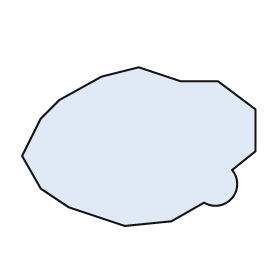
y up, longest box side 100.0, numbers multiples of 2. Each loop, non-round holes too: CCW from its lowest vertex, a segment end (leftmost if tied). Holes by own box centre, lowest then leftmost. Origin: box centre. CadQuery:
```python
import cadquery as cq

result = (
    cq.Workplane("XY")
    .moveTo(-6.0, -34.0)
    .lineTo(14.0, -32.0)
    .lineTo(28.0, -24.0)
    .threePointArc((40.0, -22.0), (40.0, -10.0))
    .lineTo(50.0, -2.0)
    .lineTo(50.0, 16.0)
    .lineTo(34.0, 28.0)
    .lineTo(18.0, 28.0)
    .lineTo(0.0, 34.0)
    .lineTo(-16.0, 30.0)
    .lineTo(-34.0, 20.0)
    .lineTo(-42.0, 12.0)
    .lineTo(-50.0, -4.0)
    .lineTo(-42.0, -18.0)
    .lineTo(-30.0, -26.0)
    .close()
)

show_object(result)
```